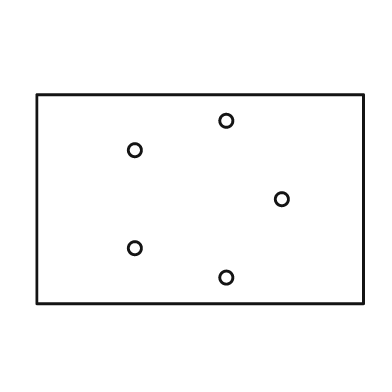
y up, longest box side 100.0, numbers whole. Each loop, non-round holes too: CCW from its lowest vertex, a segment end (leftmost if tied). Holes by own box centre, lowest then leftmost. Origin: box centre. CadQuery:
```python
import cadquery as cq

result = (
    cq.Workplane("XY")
    .moveTo(-50.0, -32.0)
    .lineTo(50.0, -32.0)
    .lineTo(50.0, 32.0)
    .lineTo(-50.0, 32.0)
    .close()
    .moveTo(8.0, -24.0)
    .circle(2.0)
    .moveTo(-20.0, -15.0)
    .circle(2.0)
    .moveTo(25.0, 0.0)
    .circle(2.0)
    .moveTo(-20.0, 15.0)
    .circle(2.0)
    .moveTo(8.0, 24.0)
    .circle(2.0)
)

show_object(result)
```